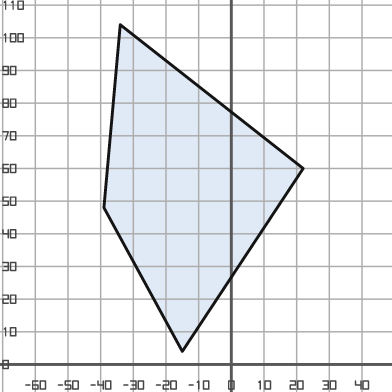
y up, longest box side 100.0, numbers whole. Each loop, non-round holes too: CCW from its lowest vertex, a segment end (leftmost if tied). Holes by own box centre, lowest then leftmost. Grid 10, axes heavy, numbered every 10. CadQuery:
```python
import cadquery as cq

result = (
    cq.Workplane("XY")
    .moveTo(-15.0, 4.0)
    .lineTo(22.0, 60.0)
    .lineTo(-34.0, 104.0)
    .lineTo(-39.0, 48.0)
    .close()
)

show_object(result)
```